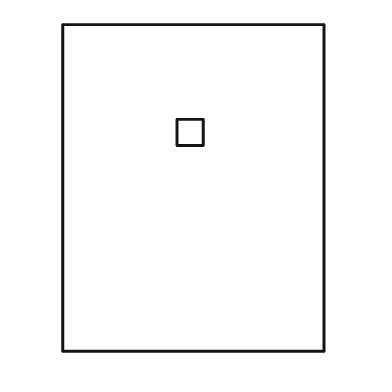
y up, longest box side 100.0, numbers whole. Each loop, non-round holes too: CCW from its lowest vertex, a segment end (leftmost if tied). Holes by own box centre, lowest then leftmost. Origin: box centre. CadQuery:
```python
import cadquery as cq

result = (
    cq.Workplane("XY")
    .moveTo(-40.0, -50.0)
    .lineTo(40.0, -50.0)
    .lineTo(40.0, 50.0)
    .lineTo(-40.0, 50.0)
    .close()
    .moveTo(-5.0, 13.0)
    .lineTo(3.0, 13.0)
    .lineTo(3.0, 21.0)
    .lineTo(-5.0, 21.0)
    .close()
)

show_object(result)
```